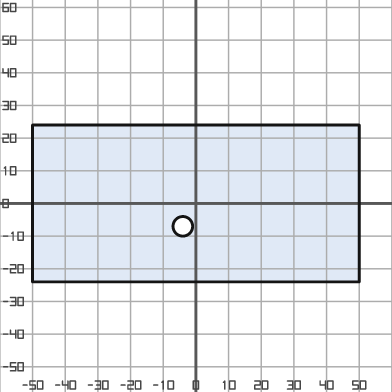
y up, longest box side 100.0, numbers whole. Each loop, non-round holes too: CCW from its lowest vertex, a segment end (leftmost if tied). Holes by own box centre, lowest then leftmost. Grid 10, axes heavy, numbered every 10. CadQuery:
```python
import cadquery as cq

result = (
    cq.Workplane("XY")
    .moveTo(-50.0, -24.0)
    .lineTo(50.0, -24.0)
    .lineTo(50.0, 24.0)
    .lineTo(-50.0, 24.0)
    .close()
    .moveTo(-4.0, -7.0)
    .circle(3.0)
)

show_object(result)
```